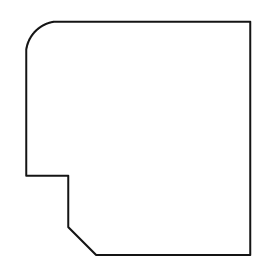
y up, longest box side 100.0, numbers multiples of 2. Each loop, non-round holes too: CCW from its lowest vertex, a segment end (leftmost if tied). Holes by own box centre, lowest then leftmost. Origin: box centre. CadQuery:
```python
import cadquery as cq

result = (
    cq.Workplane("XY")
    .moveTo(-18.0, -50.0)
    .lineTo(48.0, -50.0)
    .lineTo(48.0, 50.0)
    .lineTo(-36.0, 50.0)
    .threePointArc((-44.0, 46.0), (-48.0, 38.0))
    .lineTo(-48.0, -16.0)
    .lineTo(-30.0, -16.0)
    .lineTo(-30.0, -38.0)
    .close()
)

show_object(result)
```